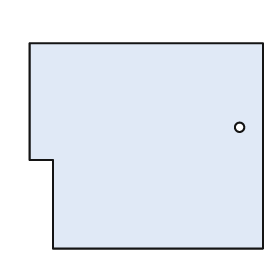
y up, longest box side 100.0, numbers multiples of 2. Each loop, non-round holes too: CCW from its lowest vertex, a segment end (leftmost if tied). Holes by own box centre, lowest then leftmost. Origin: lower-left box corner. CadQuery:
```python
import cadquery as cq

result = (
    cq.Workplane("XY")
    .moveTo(10.0, 0.0)
    .lineTo(100.0, 0.0)
    .lineTo(100.0, 88.0)
    .lineTo(0.0, 88.0)
    .lineTo(0.0, 38.0)
    .lineTo(10.0, 38.0)
    .close()
    .moveTo(90.0, 52.0)
    .circle(2.0)
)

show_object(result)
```